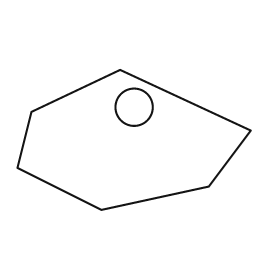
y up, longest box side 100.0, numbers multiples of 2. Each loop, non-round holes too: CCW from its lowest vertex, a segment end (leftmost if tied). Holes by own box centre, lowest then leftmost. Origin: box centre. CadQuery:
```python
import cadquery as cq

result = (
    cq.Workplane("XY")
    .moveTo(-14.0, -30.0)
    .lineTo(32.0, -20.0)
    .lineTo(50.0, 4.0)
    .lineTo(-6.0, 30.0)
    .lineTo(-44.0, 12.0)
    .lineTo(-50.0, -12.0)
    .close()
    .moveTo(0.0, 14.0)
    .circle(8.0)
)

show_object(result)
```